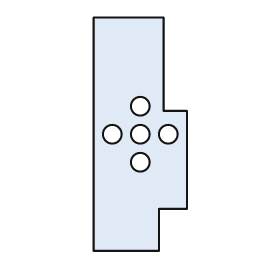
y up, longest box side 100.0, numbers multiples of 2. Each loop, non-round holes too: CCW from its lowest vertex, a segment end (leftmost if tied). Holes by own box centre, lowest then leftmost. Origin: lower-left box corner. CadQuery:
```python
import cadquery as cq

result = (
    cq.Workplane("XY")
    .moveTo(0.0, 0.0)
    .lineTo(28.0, 0.0)
    .lineTo(28.0, 18.0)
    .lineTo(40.0, 18.0)
    .lineTo(40.0, 60.0)
    .lineTo(30.0, 60.0)
    .lineTo(30.0, 100.0)
    .lineTo(0.0, 100.0)
    .close()
    .moveTo(20.0, 38.0)
    .circle(4.0)
    .moveTo(8.0, 50.0)
    .circle(4.0)
    .moveTo(20.0, 50.0)
    .circle(4.0)
    .moveTo(32.0, 50.0)
    .circle(4.0)
    .moveTo(20.0, 62.0)
    .circle(4.0)
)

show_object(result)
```